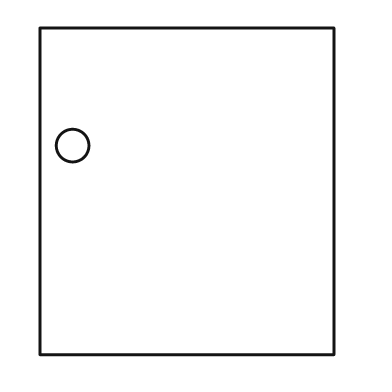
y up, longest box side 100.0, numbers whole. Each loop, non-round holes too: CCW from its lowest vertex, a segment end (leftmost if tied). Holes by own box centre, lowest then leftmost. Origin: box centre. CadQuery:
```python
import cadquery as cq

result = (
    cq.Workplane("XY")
    .moveTo(-45.0, -50.0)
    .lineTo(45.0, -50.0)
    .lineTo(45.0, 50.0)
    .lineTo(-45.0, 50.0)
    .close()
    .moveTo(-35.0, 14.0)
    .circle(5.0)
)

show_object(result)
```